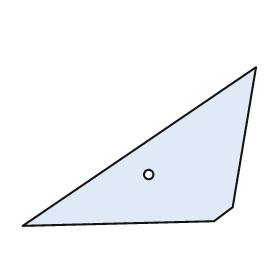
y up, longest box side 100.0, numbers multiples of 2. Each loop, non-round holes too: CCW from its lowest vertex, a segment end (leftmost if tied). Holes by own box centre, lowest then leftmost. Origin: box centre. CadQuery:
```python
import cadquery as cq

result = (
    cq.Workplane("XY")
    .moveTo(-50.0, -34.0)
    .lineTo(32.0, -32.0)
    .lineTo(40.0, -26.0)
    .lineTo(50.0, 34.0)
    .close()
    .moveTo(4.0, -12.0)
    .circle(2.0)
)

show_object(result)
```